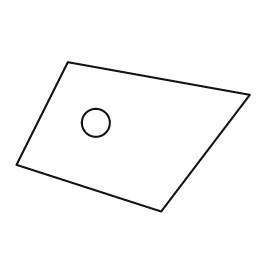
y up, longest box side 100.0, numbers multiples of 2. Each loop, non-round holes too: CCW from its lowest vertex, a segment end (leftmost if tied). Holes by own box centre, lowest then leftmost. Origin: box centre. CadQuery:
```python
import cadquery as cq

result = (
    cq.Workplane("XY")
    .moveTo(12.0, -32.0)
    .lineTo(50.0, 18.0)
    .lineTo(-28.0, 32.0)
    .lineTo(-50.0, -12.0)
    .close()
    .moveTo(-16.0, 6.0)
    .circle(6.0)
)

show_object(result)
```